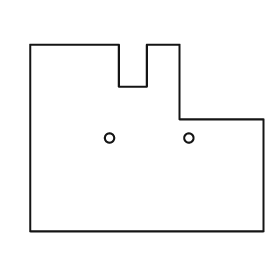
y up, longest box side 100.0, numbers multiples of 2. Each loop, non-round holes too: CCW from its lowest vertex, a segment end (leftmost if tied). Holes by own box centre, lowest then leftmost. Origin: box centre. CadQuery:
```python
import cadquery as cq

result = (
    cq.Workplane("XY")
    .moveTo(-50.0, -40.0)
    .lineTo(50.0, -40.0)
    .lineTo(50.0, 8.0)
    .lineTo(14.0, 8.0)
    .lineTo(14.0, 40.0)
    .lineTo(0.0, 40.0)
    .lineTo(0.0, 22.0)
    .lineTo(-12.0, 22.0)
    .lineTo(-12.0, 40.0)
    .lineTo(-50.0, 40.0)
    .close()
    .moveTo(-16.0, 0.0)
    .circle(2.0)
    .moveTo(18.0, 0.0)
    .circle(2.0)
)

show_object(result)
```